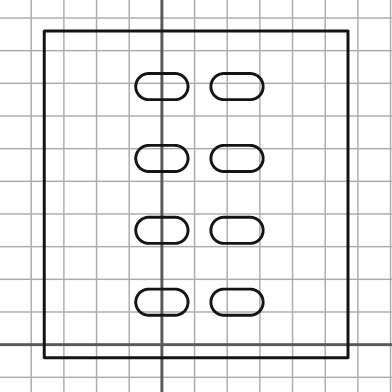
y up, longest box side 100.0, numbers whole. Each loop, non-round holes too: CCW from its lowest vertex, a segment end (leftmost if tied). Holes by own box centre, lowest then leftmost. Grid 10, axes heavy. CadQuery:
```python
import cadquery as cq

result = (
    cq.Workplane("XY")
    .moveTo(-36.0, -4.0)
    .lineTo(57.0, -4.0)
    .lineTo(57.0, 96.0)
    .lineTo(-36.0, 96.0)
    .close()
    .moveTo(-4.0, 9.0)
    .lineTo(4.0, 9.0)
    .threePointArc((8.0, 13.0), (4.0, 17.0))
    .lineTo(-4.0, 17.0)
    .threePointArc((-8.0, 13.0), (-4.0, 9.0))
    .close()
    .moveTo(19.0, 9.0)
    .lineTo(27.0, 9.0)
    .threePointArc((31.0, 13.0), (27.0, 17.0))
    .lineTo(19.0, 17.0)
    .threePointArc((15.0, 13.0), (19.0, 9.0))
    .close()
    .moveTo(-4.0, 31.0)
    .lineTo(4.0, 31.0)
    .threePointArc((8.0, 35.0), (4.0, 39.0))
    .lineTo(-4.0, 39.0)
    .threePointArc((-8.0, 35.0), (-4.0, 31.0))
    .close()
    .moveTo(19.0, 31.0)
    .lineTo(27.0, 31.0)
    .threePointArc((31.0, 35.0), (27.0, 39.0))
    .lineTo(19.0, 39.0)
    .threePointArc((15.0, 35.0), (19.0, 31.0))
    .close()
    .moveTo(-4.0, 53.0)
    .lineTo(4.0, 53.0)
    .threePointArc((8.0, 57.0), (4.0, 61.0))
    .lineTo(-4.0, 61.0)
    .threePointArc((-8.0, 57.0), (-4.0, 53.0))
    .close()
    .moveTo(19.0, 53.0)
    .lineTo(27.0, 53.0)
    .threePointArc((31.0, 57.0), (27.0, 61.0))
    .lineTo(19.0, 61.0)
    .threePointArc((15.0, 57.0), (19.0, 53.0))
    .close()
    .moveTo(-4.0, 75.0)
    .lineTo(4.0, 75.0)
    .threePointArc((8.0, 79.0), (4.0, 83.0))
    .lineTo(-4.0, 83.0)
    .threePointArc((-8.0, 79.0), (-4.0, 75.0))
    .close()
    .moveTo(19.0, 75.0)
    .lineTo(27.0, 75.0)
    .threePointArc((31.0, 79.0), (27.0, 83.0))
    .lineTo(19.0, 83.0)
    .threePointArc((15.0, 79.0), (19.0, 75.0))
    .close()
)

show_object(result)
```